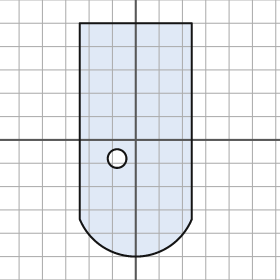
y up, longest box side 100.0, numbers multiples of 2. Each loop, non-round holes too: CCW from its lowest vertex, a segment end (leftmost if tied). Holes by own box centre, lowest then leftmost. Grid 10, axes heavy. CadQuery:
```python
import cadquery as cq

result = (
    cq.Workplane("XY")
    .moveTo(-24.0, -34.0)
    .threePointArc((0.0, -50.0), (24.0, -34.0))
    .lineTo(24.0, 50.0)
    .lineTo(-24.0, 50.0)
    .close()
    .moveTo(-8.0, -8.0)
    .circle(4.0)
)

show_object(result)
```